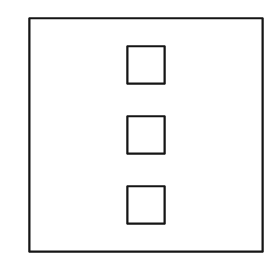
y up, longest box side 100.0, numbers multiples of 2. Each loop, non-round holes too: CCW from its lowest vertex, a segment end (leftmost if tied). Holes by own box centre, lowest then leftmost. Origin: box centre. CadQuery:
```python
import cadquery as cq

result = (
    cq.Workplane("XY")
    .moveTo(-50.0, -50.0)
    .lineTo(50.0, -50.0)
    .lineTo(50.0, 50.0)
    .lineTo(-50.0, 50.0)
    .close()
    .moveTo(-8.0, -38.0)
    .lineTo(8.0, -38.0)
    .lineTo(8.0, -22.0)
    .lineTo(-8.0, -22.0)
    .close()
    .moveTo(-8.0, -8.0)
    .lineTo(8.0, -8.0)
    .lineTo(8.0, 8.0)
    .lineTo(-8.0, 8.0)
    .close()
    .moveTo(-8.0, 22.0)
    .lineTo(8.0, 22.0)
    .lineTo(8.0, 38.0)
    .lineTo(-8.0, 38.0)
    .close()
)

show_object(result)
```